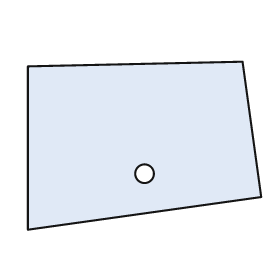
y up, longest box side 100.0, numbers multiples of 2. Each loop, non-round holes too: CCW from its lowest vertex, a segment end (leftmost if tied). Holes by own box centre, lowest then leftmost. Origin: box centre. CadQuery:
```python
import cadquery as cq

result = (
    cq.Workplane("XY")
    .moveTo(-50.0, -36.0)
    .lineTo(50.0, -22.0)
    .lineTo(42.0, 36.0)
    .lineTo(-50.0, 34.0)
    .close()
    .moveTo(0.0, -12.0)
    .circle(4.0)
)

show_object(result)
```